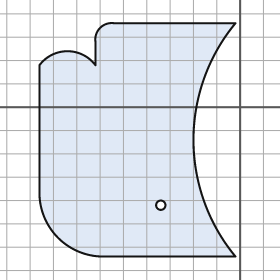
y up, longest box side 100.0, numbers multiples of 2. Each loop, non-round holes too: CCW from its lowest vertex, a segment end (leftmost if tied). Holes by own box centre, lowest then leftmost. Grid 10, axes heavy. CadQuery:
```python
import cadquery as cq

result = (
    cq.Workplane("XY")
    .moveTo(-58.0, -64.0)
    .lineTo(-2.0, -64.0)
    .threePointArc((-20.0, -14.0), (-2.0, 36.0))
    .lineTo(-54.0, 36.0)
    .threePointArc((-60.0, 34.0), (-62.0, 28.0))
    .lineTo(-62.0, 18.0)
    .threePointArc((-74.0, 24.0), (-86.0, 18.0))
    .lineTo(-86.0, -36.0)
    .threePointArc((-78.0, -56.0), (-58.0, -64.0))
    .close()
    .moveTo(-34.0, -42.0)
    .circle(2.0)
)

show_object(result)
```